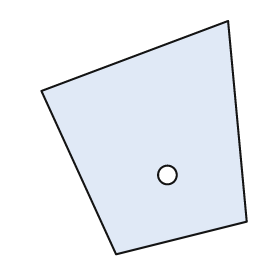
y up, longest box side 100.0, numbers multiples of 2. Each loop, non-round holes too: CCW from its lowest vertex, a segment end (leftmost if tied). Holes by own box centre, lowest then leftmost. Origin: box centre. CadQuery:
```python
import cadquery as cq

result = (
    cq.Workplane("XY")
    .moveTo(-12.0, -50.0)
    .lineTo(44.0, -36.0)
    .lineTo(36.0, 50.0)
    .lineTo(-44.0, 20.0)
    .close()
    .moveTo(10.0, -16.0)
    .circle(4.0)
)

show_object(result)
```